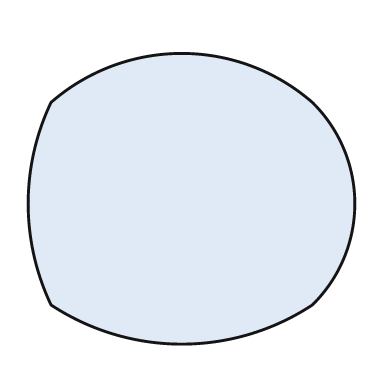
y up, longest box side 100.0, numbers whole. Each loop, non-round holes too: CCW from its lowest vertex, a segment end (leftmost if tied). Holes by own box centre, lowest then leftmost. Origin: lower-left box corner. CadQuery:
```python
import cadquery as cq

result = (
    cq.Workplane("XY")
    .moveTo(7.0, 12.0)
    .threePointArc((47.0, 0.0), (87.0, 12.0))
    .threePointArc((100.0, 43.0), (87.0, 74.0))
    .threePointArc((47.0, 89.0), (7.0, 74.0))
    .threePointArc((0.0, 43.0), (7.0, 12.0))
    .close()
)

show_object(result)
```